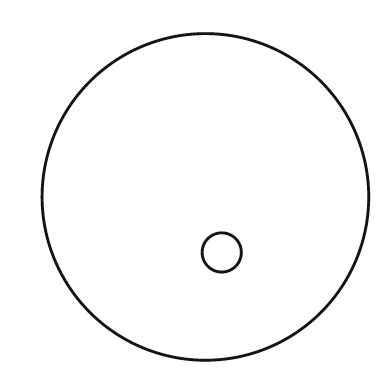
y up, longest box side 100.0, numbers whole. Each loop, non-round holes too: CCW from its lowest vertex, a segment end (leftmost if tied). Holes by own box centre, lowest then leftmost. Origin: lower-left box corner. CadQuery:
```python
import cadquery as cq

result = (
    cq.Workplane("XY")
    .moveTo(50.0, 50.0)
    .circle(50.0)
    .moveTo(55.0, 33.0)
    .circle(6.0)
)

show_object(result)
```